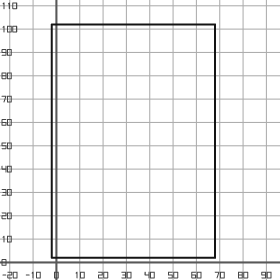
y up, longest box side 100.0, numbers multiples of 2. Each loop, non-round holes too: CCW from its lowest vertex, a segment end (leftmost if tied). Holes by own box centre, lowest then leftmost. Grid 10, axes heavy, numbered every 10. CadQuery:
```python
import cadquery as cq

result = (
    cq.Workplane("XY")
    .moveTo(-2.0, 2.0)
    .lineTo(68.0, 2.0)
    .lineTo(68.0, 102.0)
    .lineTo(-2.0, 102.0)
    .close()
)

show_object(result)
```